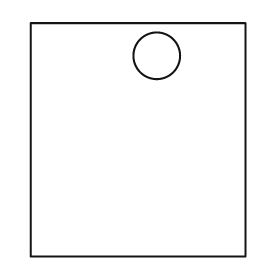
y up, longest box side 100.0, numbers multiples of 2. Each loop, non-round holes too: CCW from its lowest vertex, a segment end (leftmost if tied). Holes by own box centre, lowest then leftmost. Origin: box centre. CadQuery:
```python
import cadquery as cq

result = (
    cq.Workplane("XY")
    .moveTo(-46.0, -50.0)
    .lineTo(46.0, -50.0)
    .lineTo(46.0, 50.0)
    .lineTo(-46.0, 50.0)
    .close()
    .moveTo(8.0, 36.0)
    .circle(10.0)
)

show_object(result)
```